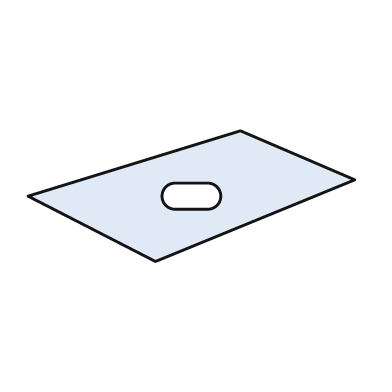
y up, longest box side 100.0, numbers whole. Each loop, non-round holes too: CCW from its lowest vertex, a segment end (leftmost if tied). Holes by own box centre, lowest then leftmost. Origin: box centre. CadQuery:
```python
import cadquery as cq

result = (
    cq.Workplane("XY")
    .moveTo(-11.0, -20.0)
    .lineTo(50.0, 5.0)
    .lineTo(15.0, 20.0)
    .lineTo(-50.0, 0.0)
    .close()
    .moveTo(-5.0, -4.0)
    .lineTo(5.0, -4.0)
    .threePointArc((9.0, 0.0), (5.0, 4.0))
    .lineTo(-5.0, 4.0)
    .threePointArc((-9.0, 0.0), (-5.0, -4.0))
    .close()
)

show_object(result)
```